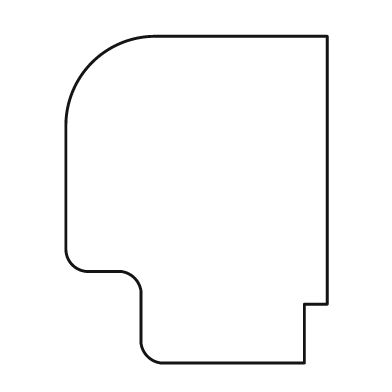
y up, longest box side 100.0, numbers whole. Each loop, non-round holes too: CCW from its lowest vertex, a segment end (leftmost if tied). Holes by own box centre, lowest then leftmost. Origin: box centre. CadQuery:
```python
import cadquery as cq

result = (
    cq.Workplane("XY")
    .moveTo(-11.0, -50.0)
    .lineTo(33.0, -50.0)
    .lineTo(33.0, -32.0)
    .lineTo(40.0, -32.0)
    .lineTo(40.0, 50.0)
    .lineTo(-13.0, 50.0)
    .threePointArc((-32.0, 42.0), (-40.0, 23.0))
    .lineTo(-40.0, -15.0)
    .threePointArc((-38.0, -20.0), (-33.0, -22.0))
    .lineTo(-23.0, -22.0)
    .threePointArc((-19.0, -24.0), (-17.0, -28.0))
    .lineTo(-17.0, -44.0)
    .threePointArc((-15.0, -48.0), (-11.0, -50.0))
    .close()
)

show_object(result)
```